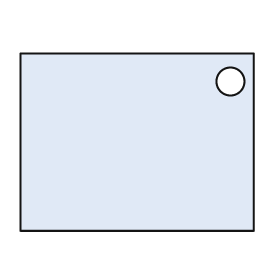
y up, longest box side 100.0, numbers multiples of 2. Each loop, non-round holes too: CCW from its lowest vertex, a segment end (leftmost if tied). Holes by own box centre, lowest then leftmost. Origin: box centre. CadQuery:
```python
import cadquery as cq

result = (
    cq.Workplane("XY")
    .moveTo(-50.0, -38.0)
    .lineTo(50.0, -38.0)
    .lineTo(50.0, 38.0)
    .lineTo(-50.0, 38.0)
    .close()
    .moveTo(40.0, 26.0)
    .circle(6.0)
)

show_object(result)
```